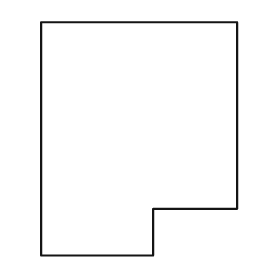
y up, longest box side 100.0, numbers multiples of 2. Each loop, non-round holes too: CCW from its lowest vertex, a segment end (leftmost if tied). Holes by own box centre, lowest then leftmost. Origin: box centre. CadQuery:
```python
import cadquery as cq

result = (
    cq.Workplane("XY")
    .moveTo(-42.0, -50.0)
    .lineTo(6.0, -50.0)
    .lineTo(6.0, -30.0)
    .lineTo(42.0, -30.0)
    .lineTo(42.0, 50.0)
    .lineTo(-42.0, 50.0)
    .close()
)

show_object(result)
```